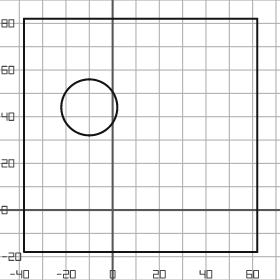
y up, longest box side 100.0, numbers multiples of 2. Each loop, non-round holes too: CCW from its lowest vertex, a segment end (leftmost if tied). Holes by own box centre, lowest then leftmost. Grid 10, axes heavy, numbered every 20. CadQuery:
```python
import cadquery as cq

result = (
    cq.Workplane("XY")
    .moveTo(-38.0, -18.0)
    .lineTo(62.0, -18.0)
    .lineTo(62.0, 82.0)
    .lineTo(-38.0, 82.0)
    .close()
    .moveTo(-10.0, 44.0)
    .circle(12.0)
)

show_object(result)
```